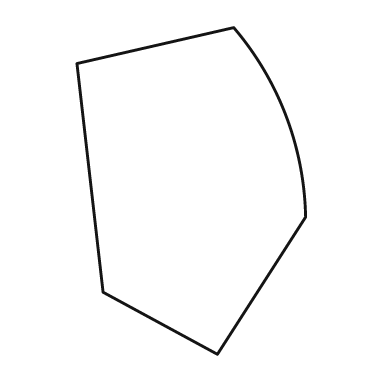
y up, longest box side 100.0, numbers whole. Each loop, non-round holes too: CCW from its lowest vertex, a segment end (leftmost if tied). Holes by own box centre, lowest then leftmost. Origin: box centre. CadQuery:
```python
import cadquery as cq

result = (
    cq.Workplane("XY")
    .moveTo(8.0, -50.0)
    .lineTo(35.0, -8.0)
    .threePointArc((29.0, 23.0), (13.0, 50.0))
    .lineTo(-35.0, 39.0)
    .lineTo(-27.0, -31.0)
    .close()
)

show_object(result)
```